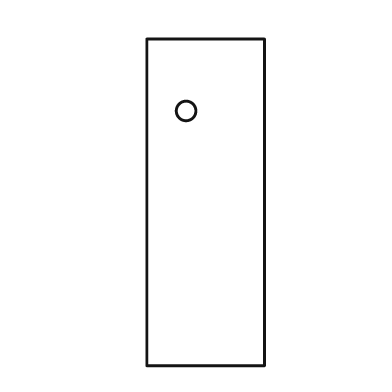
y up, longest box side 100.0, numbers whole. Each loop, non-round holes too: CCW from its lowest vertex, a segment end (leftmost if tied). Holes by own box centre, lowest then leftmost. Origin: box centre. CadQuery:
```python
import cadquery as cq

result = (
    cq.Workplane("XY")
    .moveTo(-18.0, -50.0)
    .lineTo(18.0, -50.0)
    .lineTo(18.0, 50.0)
    .lineTo(-18.0, 50.0)
    .close()
    .moveTo(-6.0, 28.0)
    .circle(3.0)
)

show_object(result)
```